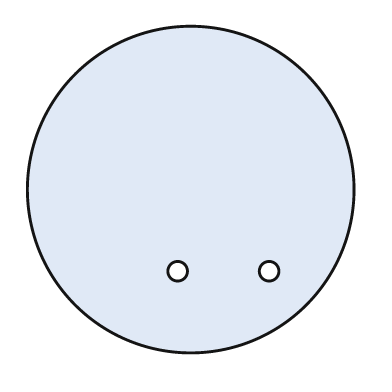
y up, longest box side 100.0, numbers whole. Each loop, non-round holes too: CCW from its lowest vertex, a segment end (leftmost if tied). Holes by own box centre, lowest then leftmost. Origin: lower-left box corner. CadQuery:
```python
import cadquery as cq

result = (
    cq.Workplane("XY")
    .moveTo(50.0, 50.0)
    .circle(50.0)
    .moveTo(46.0, 25.0)
    .circle(3.0)
    .moveTo(74.0, 25.0)
    .circle(3.0)
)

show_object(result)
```